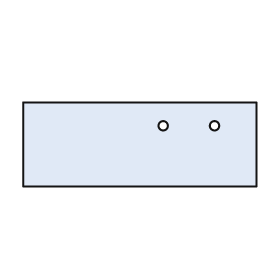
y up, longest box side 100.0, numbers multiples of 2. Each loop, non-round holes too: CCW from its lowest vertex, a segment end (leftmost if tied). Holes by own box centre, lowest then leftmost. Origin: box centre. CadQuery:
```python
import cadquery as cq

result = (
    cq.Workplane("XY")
    .moveTo(-50.0, -18.0)
    .lineTo(50.0, -18.0)
    .lineTo(50.0, 18.0)
    .lineTo(-50.0, 18.0)
    .close()
    .moveTo(10.0, 8.0)
    .circle(2.0)
    .moveTo(32.0, 8.0)
    .circle(2.0)
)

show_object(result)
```